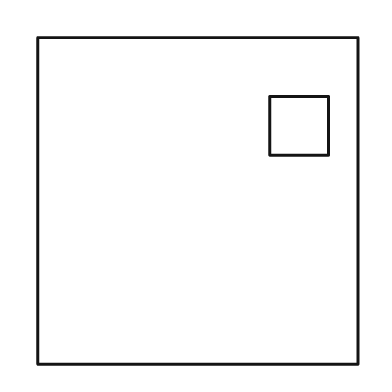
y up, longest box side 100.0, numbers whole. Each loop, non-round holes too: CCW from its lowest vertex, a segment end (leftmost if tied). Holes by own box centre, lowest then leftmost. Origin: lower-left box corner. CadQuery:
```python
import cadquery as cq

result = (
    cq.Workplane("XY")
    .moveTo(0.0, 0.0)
    .lineTo(98.0, 0.0)
    .lineTo(98.0, 100.0)
    .lineTo(0.0, 100.0)
    .close()
    .moveTo(71.0, 64.0)
    .lineTo(89.0, 64.0)
    .lineTo(89.0, 82.0)
    .lineTo(71.0, 82.0)
    .close()
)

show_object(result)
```